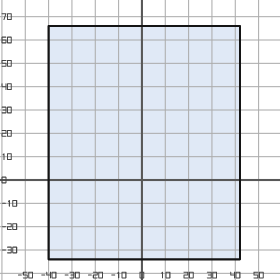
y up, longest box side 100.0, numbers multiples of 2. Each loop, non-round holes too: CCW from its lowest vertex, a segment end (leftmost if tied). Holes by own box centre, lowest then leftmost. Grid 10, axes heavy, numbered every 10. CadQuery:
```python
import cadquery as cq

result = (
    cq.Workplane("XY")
    .moveTo(-40.0, -34.0)
    .lineTo(42.0, -34.0)
    .lineTo(42.0, 66.0)
    .lineTo(-40.0, 66.0)
    .close()
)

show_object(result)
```